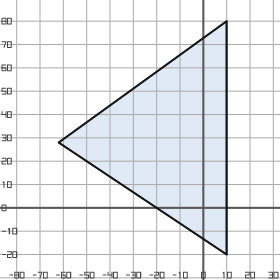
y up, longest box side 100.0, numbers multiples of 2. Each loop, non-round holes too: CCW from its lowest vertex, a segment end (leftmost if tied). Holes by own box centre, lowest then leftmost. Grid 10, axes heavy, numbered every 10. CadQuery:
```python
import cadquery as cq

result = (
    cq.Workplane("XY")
    .moveTo(10.0, -20.0)
    .lineTo(10.0, 80.0)
    .lineTo(-62.0, 28.0)
    .close()
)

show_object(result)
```